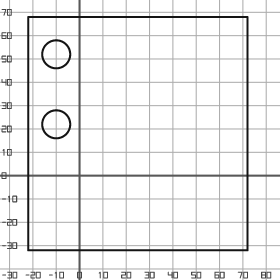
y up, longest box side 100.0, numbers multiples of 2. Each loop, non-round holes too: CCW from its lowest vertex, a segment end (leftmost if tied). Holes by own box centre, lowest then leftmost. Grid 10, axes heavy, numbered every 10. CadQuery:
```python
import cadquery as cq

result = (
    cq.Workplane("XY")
    .moveTo(-22.0, -32.0)
    .lineTo(72.0, -32.0)
    .lineTo(72.0, 68.0)
    .lineTo(-22.0, 68.0)
    .close()
    .moveTo(-10.0, 22.0)
    .circle(6.0)
    .moveTo(-10.0, 52.0)
    .circle(6.0)
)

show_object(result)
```